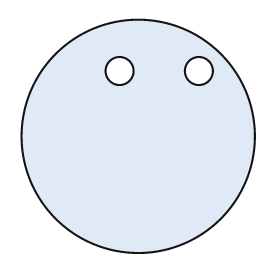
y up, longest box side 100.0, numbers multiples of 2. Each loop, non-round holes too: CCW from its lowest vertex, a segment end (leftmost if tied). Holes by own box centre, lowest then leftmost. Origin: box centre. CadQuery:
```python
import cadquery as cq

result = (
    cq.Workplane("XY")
    .moveTo(0.0, 0.0)
    .circle(50.0)
    .moveTo(-8.0, 28.0)
    .circle(6.0)
    .moveTo(26.0, 28.0)
    .circle(6.0)
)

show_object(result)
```